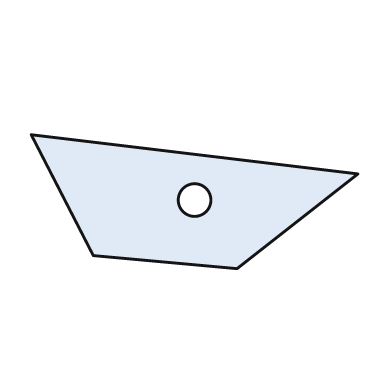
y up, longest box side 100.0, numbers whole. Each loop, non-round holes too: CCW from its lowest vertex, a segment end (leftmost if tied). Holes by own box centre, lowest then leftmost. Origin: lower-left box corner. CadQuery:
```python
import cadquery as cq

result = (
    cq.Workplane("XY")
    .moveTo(63.0, 0.0)
    .lineTo(100.0, 29.0)
    .lineTo(0.0, 41.0)
    .lineTo(19.0, 4.0)
    .close()
    .moveTo(50.0, 21.0)
    .circle(5.0)
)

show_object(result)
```